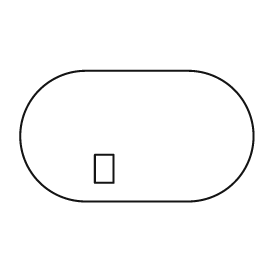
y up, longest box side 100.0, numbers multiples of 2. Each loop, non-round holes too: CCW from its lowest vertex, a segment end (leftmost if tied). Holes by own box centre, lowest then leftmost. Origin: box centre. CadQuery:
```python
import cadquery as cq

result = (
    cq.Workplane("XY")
    .moveTo(-22.0, -28.0)
    .lineTo(22.0, -28.0)
    .threePointArc((50.0, 0.0), (22.0, 28.0))
    .lineTo(-22.0, 28.0)
    .threePointArc((-50.0, 0.0), (-22.0, -28.0))
    .close()
    .moveTo(-18.0, -20.0)
    .lineTo(-10.0, -20.0)
    .lineTo(-10.0, -8.0)
    .lineTo(-18.0, -8.0)
    .close()
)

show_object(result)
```